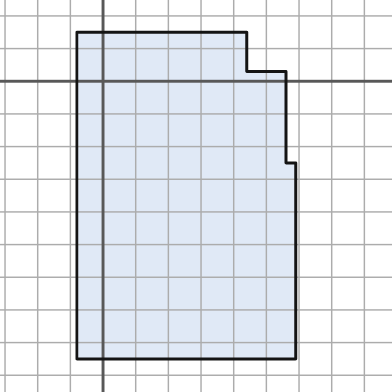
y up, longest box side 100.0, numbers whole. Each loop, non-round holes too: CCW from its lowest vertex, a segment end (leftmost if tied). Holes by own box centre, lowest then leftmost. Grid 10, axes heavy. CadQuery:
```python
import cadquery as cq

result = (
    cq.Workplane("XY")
    .moveTo(-8.0, -85.0)
    .lineTo(59.0, -85.0)
    .lineTo(59.0, -25.0)
    .lineTo(56.0, -25.0)
    .lineTo(56.0, 3.0)
    .lineTo(44.0, 3.0)
    .lineTo(44.0, 15.0)
    .lineTo(-8.0, 15.0)
    .close()
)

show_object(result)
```